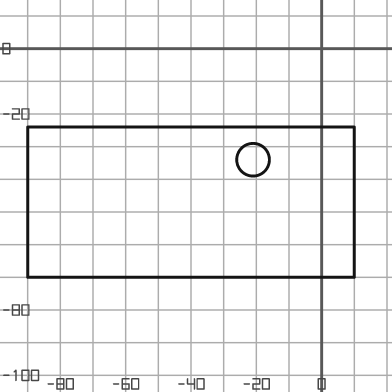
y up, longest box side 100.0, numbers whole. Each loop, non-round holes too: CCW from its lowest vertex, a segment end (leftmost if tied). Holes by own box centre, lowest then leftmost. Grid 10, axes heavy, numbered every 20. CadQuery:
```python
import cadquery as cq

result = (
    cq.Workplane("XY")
    .moveTo(-90.0, -70.0)
    .lineTo(10.0, -70.0)
    .lineTo(10.0, -24.0)
    .lineTo(-90.0, -24.0)
    .close()
    .moveTo(-21.0, -34.0)
    .circle(5.0)
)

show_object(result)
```